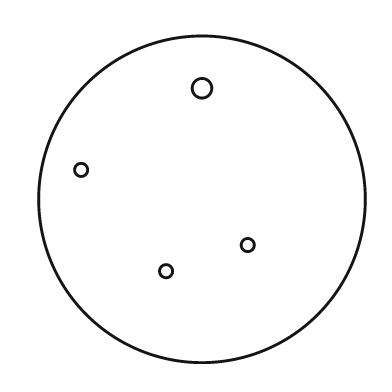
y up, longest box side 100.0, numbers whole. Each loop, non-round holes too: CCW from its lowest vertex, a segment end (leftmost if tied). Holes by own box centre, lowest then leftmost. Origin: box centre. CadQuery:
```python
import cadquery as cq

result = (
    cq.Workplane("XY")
    .moveTo(0.0, 0.0)
    .circle(50.0)
    .moveTo(-11.0, -22.0)
    .circle(2.0)
    .moveTo(14.0, -14.0)
    .circle(2.0)
    .moveTo(-37.0, 9.0)
    .circle(2.0)
    .moveTo(0.0, 34.0)
    .circle(3.0)
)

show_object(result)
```